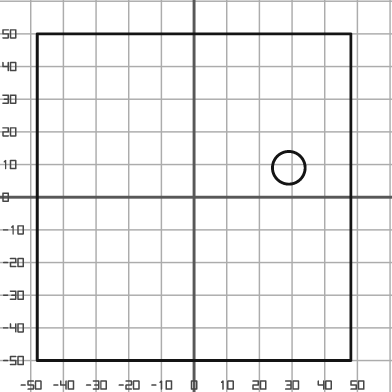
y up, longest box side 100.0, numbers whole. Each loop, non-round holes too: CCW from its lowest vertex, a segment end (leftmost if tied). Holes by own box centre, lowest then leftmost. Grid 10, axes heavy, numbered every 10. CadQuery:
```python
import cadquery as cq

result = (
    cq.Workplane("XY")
    .moveTo(-48.0, -50.0)
    .lineTo(48.0, -50.0)
    .lineTo(48.0, 50.0)
    .lineTo(-48.0, 50.0)
    .close()
    .moveTo(29.0, 9.0)
    .circle(5.0)
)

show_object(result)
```